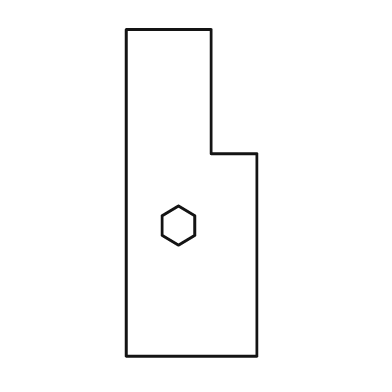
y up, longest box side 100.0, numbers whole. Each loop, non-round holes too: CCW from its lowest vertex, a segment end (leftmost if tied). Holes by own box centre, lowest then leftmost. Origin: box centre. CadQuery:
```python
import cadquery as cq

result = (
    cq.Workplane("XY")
    .moveTo(-20.0, -50.0)
    .lineTo(20.0, -50.0)
    .lineTo(20.0, 12.0)
    .lineTo(6.0, 12.0)
    .lineTo(6.0, 50.0)
    .lineTo(-20.0, 50.0)
    .close()
    .moveTo(-4.0, -16.0)
    .lineTo(1.0, -13.0)
    .lineTo(1.0, -7.0)
    .lineTo(-4.0, -4.0)
    .lineTo(-9.0, -7.0)
    .lineTo(-9.0, -13.0)
    .close()
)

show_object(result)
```